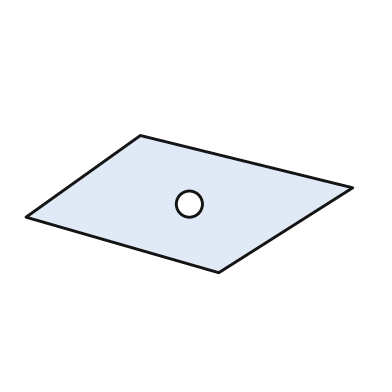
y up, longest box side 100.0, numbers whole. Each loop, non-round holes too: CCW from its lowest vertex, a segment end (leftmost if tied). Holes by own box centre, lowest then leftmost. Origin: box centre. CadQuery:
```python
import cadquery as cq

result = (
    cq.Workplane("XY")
    .moveTo(9.0, -21.0)
    .lineTo(50.0, 5.0)
    .lineTo(-15.0, 21.0)
    .lineTo(-50.0, -4.0)
    .close()
    .moveTo(0.0, 0.0)
    .circle(4.0)
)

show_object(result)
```